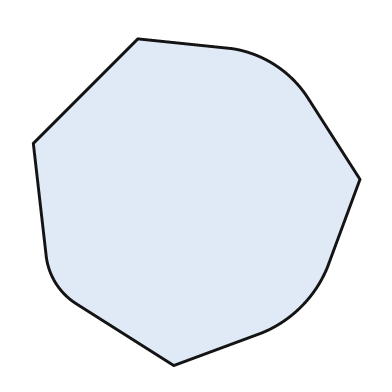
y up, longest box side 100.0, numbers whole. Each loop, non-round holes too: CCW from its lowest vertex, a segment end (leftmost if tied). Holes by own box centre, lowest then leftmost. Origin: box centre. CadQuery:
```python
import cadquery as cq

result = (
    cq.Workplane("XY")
    .moveTo(-7.0, -50.0)
    .lineTo(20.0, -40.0)
    .threePointArc((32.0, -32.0), (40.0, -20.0))
    .lineTo(50.0, 7.0)
    .lineTo(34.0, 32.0)
    .threePointArc((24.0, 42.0), (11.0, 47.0))
    .lineTo(-18.0, 50.0)
    .lineTo(-50.0, 18.0)
    .lineTo(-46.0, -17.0)
    .threePointArc((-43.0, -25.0), (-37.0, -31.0))
    .close()
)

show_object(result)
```